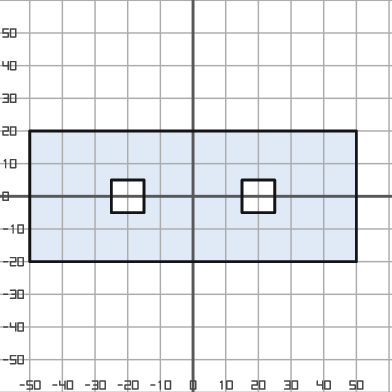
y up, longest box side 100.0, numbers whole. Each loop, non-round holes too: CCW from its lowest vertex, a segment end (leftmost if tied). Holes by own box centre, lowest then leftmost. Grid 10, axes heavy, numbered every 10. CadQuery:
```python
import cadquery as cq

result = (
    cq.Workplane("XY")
    .moveTo(-50.0, -20.0)
    .lineTo(50.0, -20.0)
    .lineTo(50.0, 20.0)
    .lineTo(-50.0, 20.0)
    .close()
    .moveTo(-25.0, -5.0)
    .lineTo(-15.0, -5.0)
    .lineTo(-15.0, 5.0)
    .lineTo(-25.0, 5.0)
    .close()
    .moveTo(15.0, -5.0)
    .lineTo(25.0, -5.0)
    .lineTo(25.0, 5.0)
    .lineTo(15.0, 5.0)
    .close()
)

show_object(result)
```